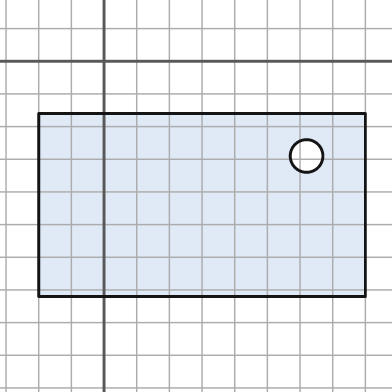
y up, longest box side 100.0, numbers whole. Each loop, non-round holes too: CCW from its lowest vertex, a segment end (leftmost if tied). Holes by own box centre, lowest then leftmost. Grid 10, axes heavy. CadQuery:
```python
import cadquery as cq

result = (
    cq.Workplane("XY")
    .moveTo(-20.0, -72.0)
    .lineTo(80.0, -72.0)
    .lineTo(80.0, -16.0)
    .lineTo(-20.0, -16.0)
    .close()
    .moveTo(62.0, -29.0)
    .circle(5.0)
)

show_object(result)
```